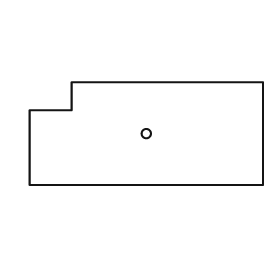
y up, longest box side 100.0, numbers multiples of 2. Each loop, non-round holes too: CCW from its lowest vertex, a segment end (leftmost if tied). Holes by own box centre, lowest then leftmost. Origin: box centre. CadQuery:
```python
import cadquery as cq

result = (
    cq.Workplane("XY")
    .moveTo(-50.0, -22.0)
    .lineTo(50.0, -22.0)
    .lineTo(50.0, 22.0)
    .lineTo(-32.0, 22.0)
    .lineTo(-32.0, 10.0)
    .lineTo(-50.0, 10.0)
    .close()
    .moveTo(0.0, 0.0)
    .circle(2.0)
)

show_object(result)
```